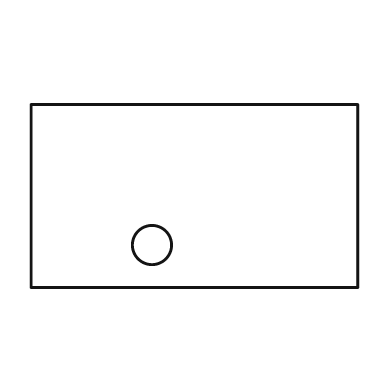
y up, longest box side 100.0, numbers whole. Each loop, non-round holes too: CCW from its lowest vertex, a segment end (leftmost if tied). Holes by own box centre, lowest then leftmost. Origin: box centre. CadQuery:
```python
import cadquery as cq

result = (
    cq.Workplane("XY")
    .moveTo(-50.0, -28.0)
    .lineTo(50.0, -28.0)
    .lineTo(50.0, 28.0)
    .lineTo(-50.0, 28.0)
    .close()
    .moveTo(-13.0, -15.0)
    .circle(6.0)
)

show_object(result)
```